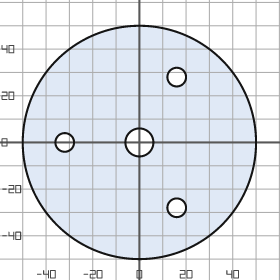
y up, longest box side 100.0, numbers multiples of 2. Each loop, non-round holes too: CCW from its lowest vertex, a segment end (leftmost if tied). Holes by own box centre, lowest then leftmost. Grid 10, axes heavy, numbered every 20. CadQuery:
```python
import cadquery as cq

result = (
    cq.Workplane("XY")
    .moveTo(0.0, 0.0)
    .circle(50.0)
    .moveTo(16.0, -28.0)
    .circle(4.0)
    .moveTo(-32.0, 0.0)
    .circle(4.0)
    .moveTo(0.0, 0.0)
    .circle(6.0)
    .moveTo(16.0, 28.0)
    .circle(4.0)
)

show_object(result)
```